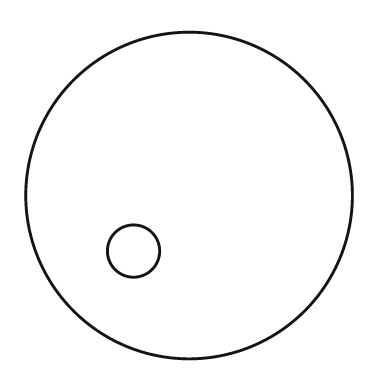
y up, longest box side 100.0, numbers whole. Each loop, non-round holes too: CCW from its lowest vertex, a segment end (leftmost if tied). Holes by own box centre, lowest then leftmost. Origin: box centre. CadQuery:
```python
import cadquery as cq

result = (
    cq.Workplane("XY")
    .moveTo(0.0, 0.0)
    .circle(50.0)
    .moveTo(-17.0, -17.0)
    .circle(8.0)
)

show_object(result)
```